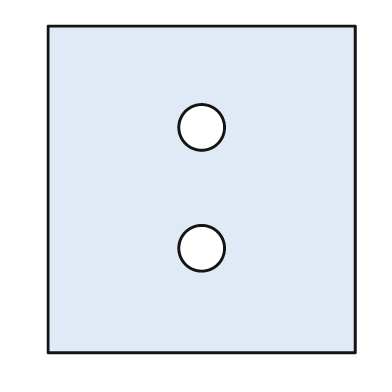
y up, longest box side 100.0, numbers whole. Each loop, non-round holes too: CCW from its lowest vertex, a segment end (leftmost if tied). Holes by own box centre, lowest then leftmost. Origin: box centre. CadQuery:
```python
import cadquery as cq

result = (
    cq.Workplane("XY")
    .moveTo(-47.0, -50.0)
    .lineTo(47.0, -50.0)
    .lineTo(47.0, 50.0)
    .lineTo(-47.0, 50.0)
    .close()
    .moveTo(0.0, -18.0)
    .circle(7.0)
    .moveTo(0.0, 19.0)
    .circle(7.0)
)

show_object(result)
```